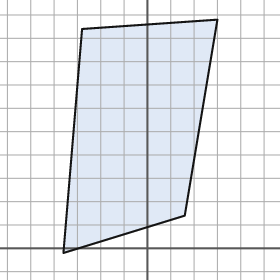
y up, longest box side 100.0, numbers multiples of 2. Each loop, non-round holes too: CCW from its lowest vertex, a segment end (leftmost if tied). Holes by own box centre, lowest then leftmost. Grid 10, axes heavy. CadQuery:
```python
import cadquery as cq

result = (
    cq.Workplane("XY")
    .moveTo(-36.0, -2.0)
    .lineTo(16.0, 14.0)
    .lineTo(30.0, 98.0)
    .lineTo(-28.0, 94.0)
    .close()
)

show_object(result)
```